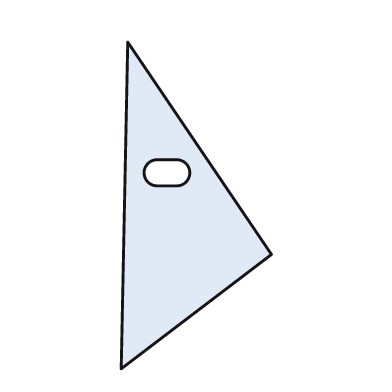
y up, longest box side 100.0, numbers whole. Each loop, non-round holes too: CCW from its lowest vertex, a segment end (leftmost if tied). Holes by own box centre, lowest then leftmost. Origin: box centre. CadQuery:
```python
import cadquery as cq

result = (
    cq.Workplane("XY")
    .moveTo(-23.0, -50.0)
    .lineTo(23.0, -15.0)
    .lineTo(-21.0, 50.0)
    .close()
    .moveTo(-12.0, 6.0)
    .lineTo(-6.0, 6.0)
    .threePointArc((-2.0, 10.0), (-6.0, 14.0))
    .lineTo(-12.0, 14.0)
    .threePointArc((-16.0, 10.0), (-12.0, 6.0))
    .close()
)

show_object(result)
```